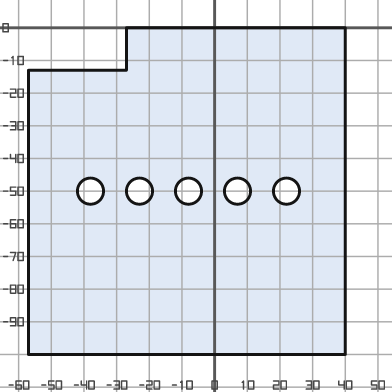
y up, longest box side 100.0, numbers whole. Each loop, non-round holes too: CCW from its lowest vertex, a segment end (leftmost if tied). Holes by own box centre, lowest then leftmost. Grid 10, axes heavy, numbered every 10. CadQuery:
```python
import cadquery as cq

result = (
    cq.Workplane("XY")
    .moveTo(-57.0, -100.0)
    .lineTo(40.0, -100.0)
    .lineTo(40.0, 0.0)
    .lineTo(-27.0, 0.0)
    .lineTo(-27.0, -13.0)
    .lineTo(-57.0, -13.0)
    .close()
    .moveTo(-38.0, -50.0)
    .circle(4.0)
    .moveTo(-23.0, -50.0)
    .circle(4.0)
    .moveTo(-8.0, -50.0)
    .circle(4.0)
    .moveTo(7.0, -50.0)
    .circle(4.0)
    .moveTo(22.0, -50.0)
    .circle(4.0)
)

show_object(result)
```